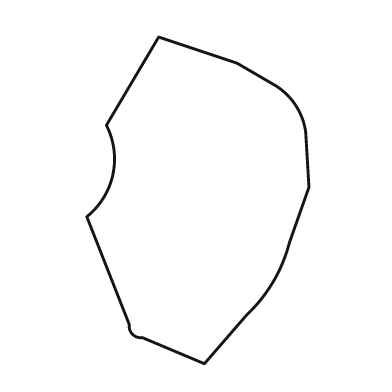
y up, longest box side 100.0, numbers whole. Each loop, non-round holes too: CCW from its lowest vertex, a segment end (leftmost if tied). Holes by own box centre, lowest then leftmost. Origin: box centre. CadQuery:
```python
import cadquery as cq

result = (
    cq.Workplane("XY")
    .moveTo(2.0, -50.0)
    .lineTo(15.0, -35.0)
    .threePointArc((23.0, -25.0), (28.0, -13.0))
    .lineTo(34.0, 4.0)
    .lineTo(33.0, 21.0)
    .threePointArc((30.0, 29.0), (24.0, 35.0))
    .lineTo(12.0, 42.0)
    .lineTo(-12.0, 50.0)
    .lineTo(-28.0, 23.0)
    .threePointArc((-26.0, 8.0), (-34.0, -5.0))
    .lineTo(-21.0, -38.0)
    .threePointArc((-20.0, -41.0), (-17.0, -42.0))
    .close()
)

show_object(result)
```